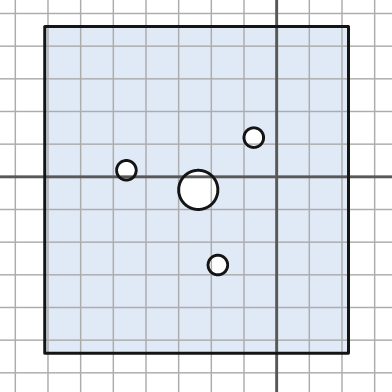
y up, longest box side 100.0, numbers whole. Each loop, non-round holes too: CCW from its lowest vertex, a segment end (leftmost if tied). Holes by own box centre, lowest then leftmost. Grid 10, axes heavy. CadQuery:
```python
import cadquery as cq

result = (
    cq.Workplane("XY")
    .moveTo(-71.0, -54.0)
    .lineTo(22.0, -54.0)
    .lineTo(22.0, 46.0)
    .lineTo(-71.0, 46.0)
    .close()
    .moveTo(-18.0, -27.0)
    .circle(3.0)
    .moveTo(-24.0, -4.0)
    .circle(6.0)
    .moveTo(-46.0, 2.0)
    .circle(3.0)
    .moveTo(-7.0, 12.0)
    .circle(3.0)
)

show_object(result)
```